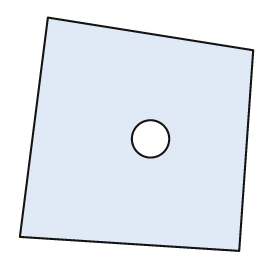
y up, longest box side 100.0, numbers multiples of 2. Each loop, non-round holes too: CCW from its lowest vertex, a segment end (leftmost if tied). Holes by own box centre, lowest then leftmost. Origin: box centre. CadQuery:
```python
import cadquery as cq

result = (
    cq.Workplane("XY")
    .moveTo(44.0, -50.0)
    .lineTo(50.0, 36.0)
    .lineTo(-38.0, 50.0)
    .lineTo(-50.0, -44.0)
    .close()
    .moveTo(6.0, -2.0)
    .circle(8.0)
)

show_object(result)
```